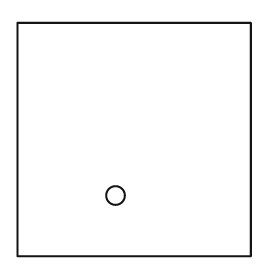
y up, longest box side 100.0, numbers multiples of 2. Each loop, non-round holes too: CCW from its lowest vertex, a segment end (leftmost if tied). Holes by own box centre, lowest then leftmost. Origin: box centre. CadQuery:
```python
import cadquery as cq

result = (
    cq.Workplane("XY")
    .moveTo(-50.0, -50.0)
    .lineTo(50.0, -50.0)
    .lineTo(50.0, 50.0)
    .lineTo(-50.0, 50.0)
    .close()
    .moveTo(-8.0, -24.0)
    .circle(4.0)
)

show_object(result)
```